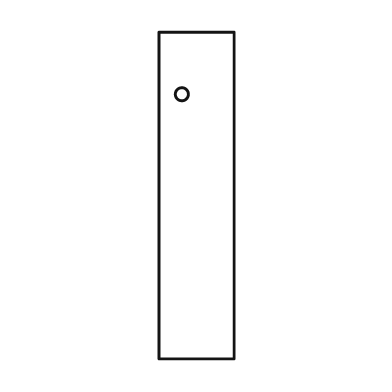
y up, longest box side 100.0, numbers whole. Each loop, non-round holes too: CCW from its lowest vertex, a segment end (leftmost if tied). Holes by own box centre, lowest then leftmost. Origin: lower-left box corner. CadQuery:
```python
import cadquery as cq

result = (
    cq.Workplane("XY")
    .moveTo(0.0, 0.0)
    .lineTo(23.0, 0.0)
    .lineTo(23.0, 100.0)
    .lineTo(0.0, 100.0)
    .close()
    .moveTo(7.0, 81.0)
    .circle(2.0)
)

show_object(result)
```